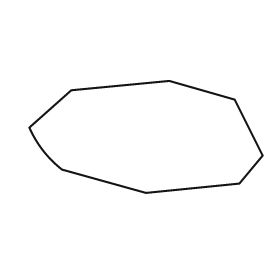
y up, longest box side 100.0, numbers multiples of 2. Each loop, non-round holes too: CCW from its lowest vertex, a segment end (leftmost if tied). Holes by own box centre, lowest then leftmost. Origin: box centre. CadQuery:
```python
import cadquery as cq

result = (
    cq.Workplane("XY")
    .moveTo(0.0, -24.0)
    .lineTo(40.0, -20.0)
    .lineTo(50.0, -8.0)
    .lineTo(38.0, 16.0)
    .lineTo(10.0, 24.0)
    .lineTo(-32.0, 20.0)
    .lineTo(-50.0, 4.0)
    .threePointArc((-44.0, -6.0), (-36.0, -14.0))
    .close()
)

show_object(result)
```